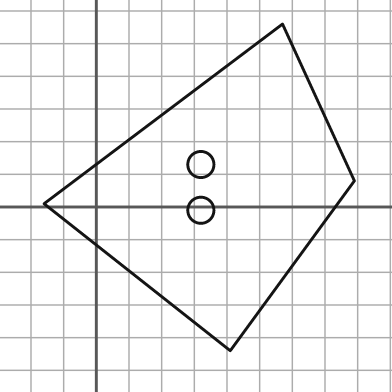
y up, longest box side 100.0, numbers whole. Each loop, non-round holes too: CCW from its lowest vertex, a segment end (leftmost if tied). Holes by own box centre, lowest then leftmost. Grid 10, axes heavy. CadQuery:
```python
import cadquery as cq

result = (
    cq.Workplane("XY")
    .moveTo(41.0, -44.0)
    .lineTo(79.0, 8.0)
    .lineTo(57.0, 56.0)
    .lineTo(-16.0, 1.0)
    .close()
    .moveTo(32.0, -1.0)
    .circle(4.0)
    .moveTo(32.0, 13.0)
    .circle(4.0)
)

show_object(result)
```